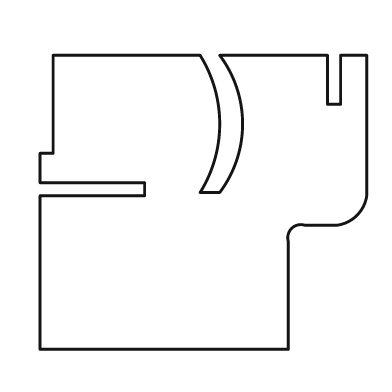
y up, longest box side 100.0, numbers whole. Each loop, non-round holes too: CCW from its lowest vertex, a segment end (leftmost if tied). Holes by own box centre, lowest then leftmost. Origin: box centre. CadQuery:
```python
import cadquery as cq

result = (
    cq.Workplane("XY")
    .moveTo(-50.0, -45.0)
    .lineTo(26.0, -45.0)
    .lineTo(26.0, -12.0)
    .threePointArc((27.0, -8.0), (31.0, -7.0))
    .lineTo(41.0, -7.0)
    .threePointArc((47.0, -4.0), (50.0, 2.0))
    .lineTo(50.0, 45.0)
    .lineTo(42.0, 45.0)
    .lineTo(42.0, 30.0)
    .lineTo(38.0, 30.0)
    .lineTo(38.0, 45.0)
    .lineTo(5.0, 45.0)
    .threePointArc((12.0, 24.0), (5.0, 3.0))
    .lineTo(-1.0, 3.0)
    .threePointArc((5.0, 24.0), (-1.0, 45.0))
    .lineTo(-46.0, 45.0)
    .lineTo(-46.0, 15.0)
    .lineTo(-50.0, 15.0)
    .lineTo(-50.0, 6.0)
    .lineTo(-18.0, 6.0)
    .lineTo(-18.0, 2.0)
    .lineTo(-50.0, 2.0)
    .close()
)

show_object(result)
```